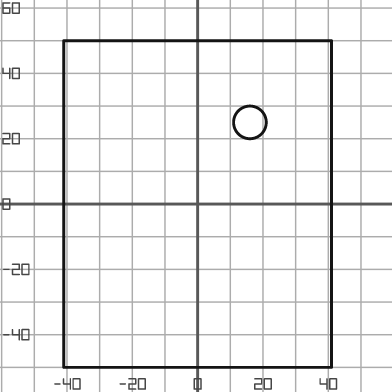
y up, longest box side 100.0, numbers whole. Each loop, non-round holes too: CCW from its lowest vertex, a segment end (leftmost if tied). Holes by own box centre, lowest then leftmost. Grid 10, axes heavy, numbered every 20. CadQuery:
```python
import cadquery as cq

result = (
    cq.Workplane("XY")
    .moveTo(-41.0, -50.0)
    .lineTo(41.0, -50.0)
    .lineTo(41.0, 50.0)
    .lineTo(-41.0, 50.0)
    .close()
    .moveTo(16.0, 25.0)
    .circle(5.0)
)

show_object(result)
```